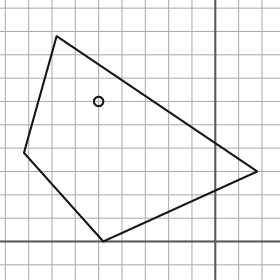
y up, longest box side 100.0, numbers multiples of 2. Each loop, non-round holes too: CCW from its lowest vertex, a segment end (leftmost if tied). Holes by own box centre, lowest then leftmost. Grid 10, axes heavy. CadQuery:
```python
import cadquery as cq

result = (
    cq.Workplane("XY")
    .moveTo(-48.0, 0.0)
    .lineTo(18.0, 30.0)
    .lineTo(-68.0, 88.0)
    .lineTo(-82.0, 38.0)
    .close()
    .moveTo(-50.0, 60.0)
    .circle(2.0)
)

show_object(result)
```